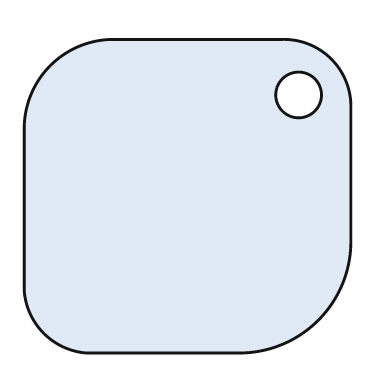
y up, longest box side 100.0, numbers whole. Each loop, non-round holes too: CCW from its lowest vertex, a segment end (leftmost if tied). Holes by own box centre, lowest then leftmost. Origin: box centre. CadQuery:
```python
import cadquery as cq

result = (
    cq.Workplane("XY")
    .moveTo(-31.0, -48.0)
    .lineTo(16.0, -48.0)
    .threePointArc((40.0, -38.0), (50.0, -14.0))
    .lineTo(50.0, 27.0)
    .threePointArc((44.0, 42.0), (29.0, 48.0))
    .lineTo(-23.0, 48.0)
    .threePointArc((-42.0, 40.0), (-50.0, 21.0))
    .lineTo(-50.0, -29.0)
    .threePointArc((-44.0, -42.0), (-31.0, -48.0))
    .close()
    .moveTo(34.0, 31.0)
    .circle(7.0)
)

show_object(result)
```